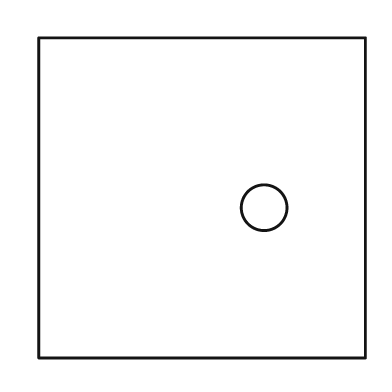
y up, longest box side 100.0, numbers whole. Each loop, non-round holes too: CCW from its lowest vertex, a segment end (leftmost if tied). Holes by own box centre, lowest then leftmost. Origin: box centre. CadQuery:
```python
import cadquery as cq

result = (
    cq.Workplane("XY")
    .moveTo(-50.0, -49.0)
    .lineTo(50.0, -49.0)
    .lineTo(50.0, 49.0)
    .lineTo(-50.0, 49.0)
    .close()
    .moveTo(19.0, -3.0)
    .circle(7.0)
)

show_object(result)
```